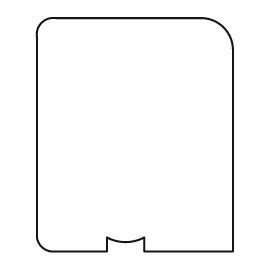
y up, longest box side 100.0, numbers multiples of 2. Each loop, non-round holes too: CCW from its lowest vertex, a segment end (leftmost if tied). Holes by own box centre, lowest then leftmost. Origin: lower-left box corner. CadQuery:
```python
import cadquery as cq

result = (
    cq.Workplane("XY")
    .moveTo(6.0, 0.0)
    .lineTo(30.0, 0.0)
    .lineTo(30.0, 6.0)
    .threePointArc((38.0, 4.0), (46.0, 6.0))
    .lineTo(46.0, 0.0)
    .lineTo(84.0, 0.0)
    .lineTo(84.0, 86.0)
    .threePointArc((80.0, 96.0), (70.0, 100.0))
    .lineTo(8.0, 100.0)
    .threePointArc((2.0, 98.0), (0.0, 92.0))
    .lineTo(0.0, 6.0)
    .threePointArc((2.0, 2.0), (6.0, 0.0))
    .close()
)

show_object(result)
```